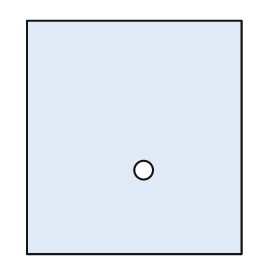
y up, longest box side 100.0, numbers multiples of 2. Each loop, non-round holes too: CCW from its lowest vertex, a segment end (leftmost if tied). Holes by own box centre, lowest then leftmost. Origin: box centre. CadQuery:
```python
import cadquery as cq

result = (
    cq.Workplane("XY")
    .moveTo(-46.0, -50.0)
    .lineTo(46.0, -50.0)
    .lineTo(46.0, 50.0)
    .lineTo(-46.0, 50.0)
    .close()
    .moveTo(4.0, -14.0)
    .circle(4.0)
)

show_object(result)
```